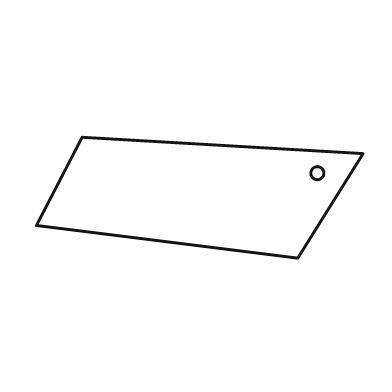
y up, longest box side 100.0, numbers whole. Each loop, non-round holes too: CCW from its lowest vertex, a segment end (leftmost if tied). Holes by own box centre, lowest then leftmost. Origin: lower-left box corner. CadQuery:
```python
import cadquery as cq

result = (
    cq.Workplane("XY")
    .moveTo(80.0, 0.0)
    .lineTo(100.0, 32.0)
    .lineTo(14.0, 37.0)
    .lineTo(0.0, 10.0)
    .close()
    .moveTo(86.0, 26.0)
    .circle(2.0)
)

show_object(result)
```